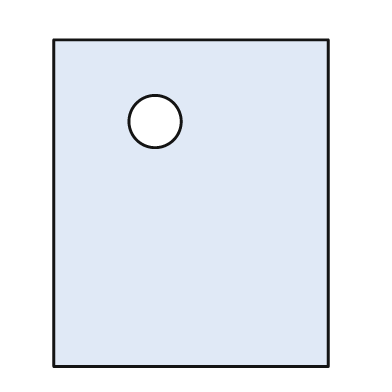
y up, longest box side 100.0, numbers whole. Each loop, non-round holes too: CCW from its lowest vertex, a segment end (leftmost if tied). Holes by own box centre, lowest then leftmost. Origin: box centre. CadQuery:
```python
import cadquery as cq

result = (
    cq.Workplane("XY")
    .moveTo(-42.0, -50.0)
    .lineTo(42.0, -50.0)
    .lineTo(42.0, 50.0)
    .lineTo(-42.0, 50.0)
    .close()
    .moveTo(-11.0, 25.0)
    .circle(8.0)
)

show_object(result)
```